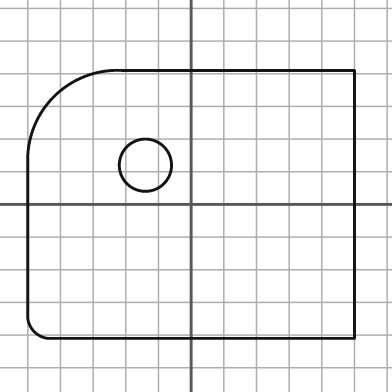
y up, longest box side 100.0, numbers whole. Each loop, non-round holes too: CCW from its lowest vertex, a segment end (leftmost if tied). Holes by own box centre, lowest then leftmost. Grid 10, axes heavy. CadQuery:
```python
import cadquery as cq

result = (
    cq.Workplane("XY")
    .moveTo(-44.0, -41.0)
    .lineTo(50.0, -41.0)
    .lineTo(50.0, 41.0)
    .lineTo(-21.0, 41.0)
    .threePointArc((-42.0, 33.0), (-50.0, 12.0))
    .lineTo(-50.0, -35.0)
    .threePointArc((-48.0, -39.0), (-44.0, -41.0))
    .close()
    .moveTo(-14.0, 12.0)
    .circle(8.0)
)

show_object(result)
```